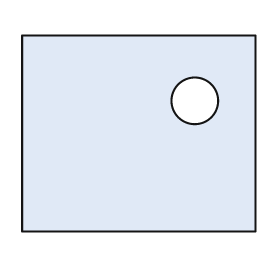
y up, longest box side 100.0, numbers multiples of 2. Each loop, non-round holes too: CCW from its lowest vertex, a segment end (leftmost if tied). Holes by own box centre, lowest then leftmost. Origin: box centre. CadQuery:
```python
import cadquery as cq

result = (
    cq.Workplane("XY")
    .moveTo(-50.0, -42.0)
    .lineTo(50.0, -42.0)
    .lineTo(50.0, 42.0)
    .lineTo(-50.0, 42.0)
    .close()
    .moveTo(24.0, 14.0)
    .circle(10.0)
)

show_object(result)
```